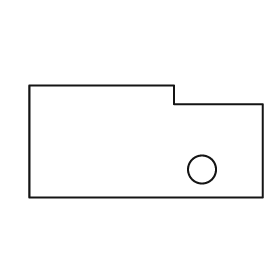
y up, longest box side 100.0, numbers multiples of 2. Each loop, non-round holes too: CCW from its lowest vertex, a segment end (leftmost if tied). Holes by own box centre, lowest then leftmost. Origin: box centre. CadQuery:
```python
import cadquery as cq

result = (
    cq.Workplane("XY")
    .moveTo(-50.0, -24.0)
    .lineTo(50.0, -24.0)
    .lineTo(50.0, 16.0)
    .lineTo(12.0, 16.0)
    .lineTo(12.0, 24.0)
    .lineTo(-50.0, 24.0)
    .close()
    .moveTo(24.0, -12.0)
    .circle(6.0)
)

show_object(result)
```